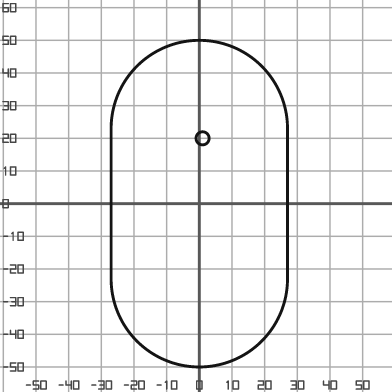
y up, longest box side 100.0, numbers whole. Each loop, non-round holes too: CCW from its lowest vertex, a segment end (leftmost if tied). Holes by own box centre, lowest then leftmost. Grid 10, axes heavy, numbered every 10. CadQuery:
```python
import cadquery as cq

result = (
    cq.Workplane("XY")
    .moveTo(-27.0, -23.0)
    .threePointArc((0.0, -50.0), (27.0, -23.0))
    .lineTo(27.0, 23.0)
    .threePointArc((0.0, 50.0), (-27.0, 23.0))
    .close()
    .moveTo(1.0, 20.0)
    .circle(2.0)
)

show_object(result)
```